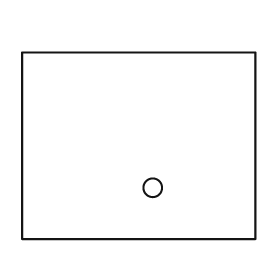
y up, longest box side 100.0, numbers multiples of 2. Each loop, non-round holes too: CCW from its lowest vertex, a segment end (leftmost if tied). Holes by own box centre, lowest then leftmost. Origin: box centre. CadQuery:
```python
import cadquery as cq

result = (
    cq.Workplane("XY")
    .moveTo(-50.0, -40.0)
    .lineTo(50.0, -40.0)
    .lineTo(50.0, 40.0)
    .lineTo(-50.0, 40.0)
    .close()
    .moveTo(6.0, -18.0)
    .circle(4.0)
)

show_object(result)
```